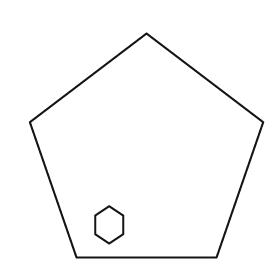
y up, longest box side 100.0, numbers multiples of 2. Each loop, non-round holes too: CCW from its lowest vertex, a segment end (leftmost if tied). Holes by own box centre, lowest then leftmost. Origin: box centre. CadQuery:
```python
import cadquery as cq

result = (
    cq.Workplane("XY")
    .moveTo(-30.0, -48.0)
    .lineTo(30.0, -48.0)
    .lineTo(50.0, 10.0)
    .lineTo(0.0, 48.0)
    .lineTo(-50.0, 10.0)
    .close()
    .moveTo(-16.0, -42.0)
    .lineTo(-10.0, -38.0)
    .lineTo(-10.0, -30.0)
    .lineTo(-16.0, -26.0)
    .lineTo(-22.0, -30.0)
    .lineTo(-22.0, -38.0)
    .close()
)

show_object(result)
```